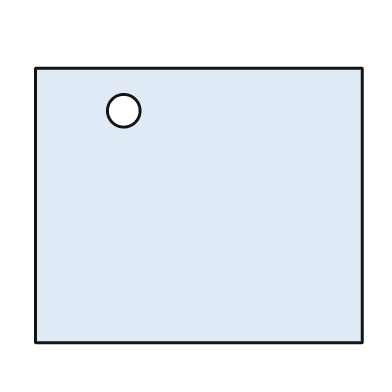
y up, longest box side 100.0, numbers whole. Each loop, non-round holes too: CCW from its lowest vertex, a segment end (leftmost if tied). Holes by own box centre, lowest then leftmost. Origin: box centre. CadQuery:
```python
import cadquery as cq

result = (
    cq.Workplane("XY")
    .moveTo(-50.0, -42.0)
    .lineTo(50.0, -42.0)
    .lineTo(50.0, 42.0)
    .lineTo(-50.0, 42.0)
    .close()
    .moveTo(-23.0, 29.0)
    .circle(5.0)
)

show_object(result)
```